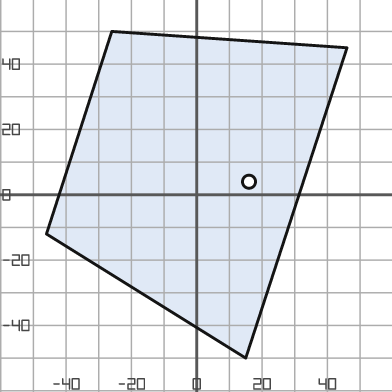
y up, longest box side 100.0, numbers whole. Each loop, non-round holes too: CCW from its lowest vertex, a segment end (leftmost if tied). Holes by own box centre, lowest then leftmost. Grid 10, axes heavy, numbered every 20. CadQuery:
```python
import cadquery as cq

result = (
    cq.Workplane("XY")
    .moveTo(15.0, -50.0)
    .lineTo(46.0, 45.0)
    .lineTo(-26.0, 50.0)
    .lineTo(-46.0, -12.0)
    .close()
    .moveTo(16.0, 4.0)
    .circle(2.0)
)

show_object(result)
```